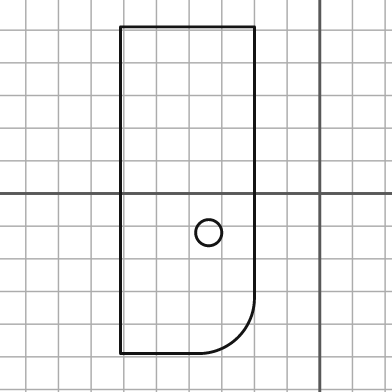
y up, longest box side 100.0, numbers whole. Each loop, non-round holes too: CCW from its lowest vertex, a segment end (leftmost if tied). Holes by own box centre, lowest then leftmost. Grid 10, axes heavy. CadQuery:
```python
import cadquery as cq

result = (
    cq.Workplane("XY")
    .moveTo(-61.0, -49.0)
    .lineTo(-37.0, -49.0)
    .threePointArc((-25.0, -44.0), (-20.0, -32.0))
    .lineTo(-20.0, 51.0)
    .lineTo(-61.0, 51.0)
    .close()
    .moveTo(-34.0, -12.0)
    .circle(4.0)
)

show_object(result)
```